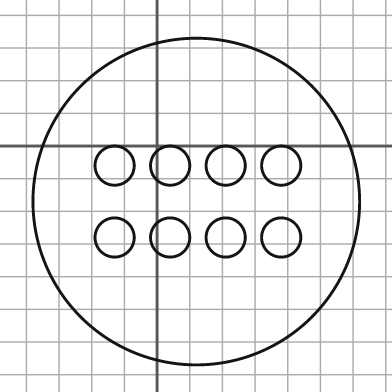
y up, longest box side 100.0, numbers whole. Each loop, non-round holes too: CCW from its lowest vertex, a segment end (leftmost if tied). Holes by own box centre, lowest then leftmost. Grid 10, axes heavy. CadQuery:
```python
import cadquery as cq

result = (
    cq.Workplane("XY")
    .moveTo(12.0, -17.0)
    .circle(50.0)
    .moveTo(-13.0, -28.0)
    .circle(6.0)
    .moveTo(4.0, -28.0)
    .circle(6.0)
    .moveTo(21.0, -28.0)
    .circle(6.0)
    .moveTo(38.0, -28.0)
    .circle(6.0)
    .moveTo(-13.0, -6.0)
    .circle(6.0)
    .moveTo(4.0, -6.0)
    .circle(6.0)
    .moveTo(21.0, -6.0)
    .circle(6.0)
    .moveTo(38.0, -6.0)
    .circle(6.0)
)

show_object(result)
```